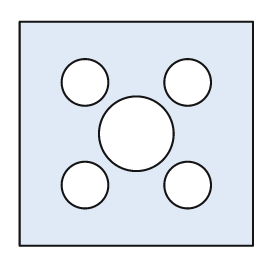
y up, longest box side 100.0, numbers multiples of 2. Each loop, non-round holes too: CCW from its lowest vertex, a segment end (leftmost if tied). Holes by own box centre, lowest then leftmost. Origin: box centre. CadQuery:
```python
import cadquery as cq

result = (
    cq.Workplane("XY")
    .moveTo(-50.0, -48.0)
    .lineTo(50.0, -48.0)
    .lineTo(50.0, 48.0)
    .lineTo(-50.0, 48.0)
    .close()
    .moveTo(-22.0, -22.0)
    .circle(10.0)
    .moveTo(22.0, -22.0)
    .circle(10.0)
    .moveTo(0.0, 0.0)
    .circle(16.0)
    .moveTo(-22.0, 22.0)
    .circle(10.0)
    .moveTo(22.0, 22.0)
    .circle(10.0)
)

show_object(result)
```